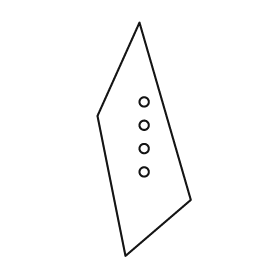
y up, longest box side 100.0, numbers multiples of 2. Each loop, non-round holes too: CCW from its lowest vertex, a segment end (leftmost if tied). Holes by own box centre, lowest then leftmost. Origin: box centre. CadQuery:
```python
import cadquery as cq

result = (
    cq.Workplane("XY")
    .moveTo(-8.0, -50.0)
    .lineTo(20.0, -26.0)
    .lineTo(-2.0, 50.0)
    .lineTo(-20.0, 10.0)
    .close()
    .moveTo(0.0, -14.0)
    .circle(2.0)
    .moveTo(0.0, -4.0)
    .circle(2.0)
    .moveTo(0.0, 6.0)
    .circle(2.0)
    .moveTo(0.0, 16.0)
    .circle(2.0)
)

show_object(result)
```